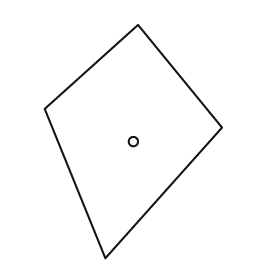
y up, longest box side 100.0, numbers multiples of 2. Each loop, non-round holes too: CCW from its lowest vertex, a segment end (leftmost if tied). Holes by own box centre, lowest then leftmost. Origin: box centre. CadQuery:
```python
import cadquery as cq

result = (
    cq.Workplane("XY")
    .moveTo(-12.0, -50.0)
    .lineTo(38.0, 6.0)
    .lineTo(2.0, 50.0)
    .lineTo(-38.0, 14.0)
    .close()
    .moveTo(0.0, 0.0)
    .circle(2.0)
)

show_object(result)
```